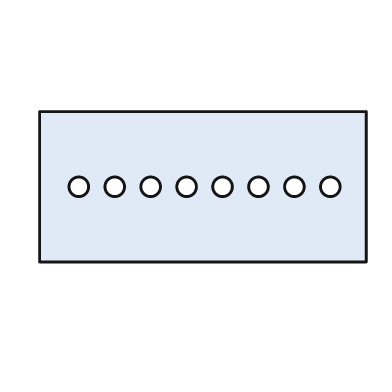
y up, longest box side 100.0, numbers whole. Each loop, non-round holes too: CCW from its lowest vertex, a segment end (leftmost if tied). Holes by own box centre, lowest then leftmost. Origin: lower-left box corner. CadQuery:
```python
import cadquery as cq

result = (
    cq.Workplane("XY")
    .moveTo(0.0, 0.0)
    .lineTo(100.0, 0.0)
    .lineTo(100.0, 46.0)
    .lineTo(0.0, 46.0)
    .close()
    .moveTo(12.0, 23.0)
    .circle(3.0)
    .moveTo(23.0, 23.0)
    .circle(3.0)
    .moveTo(34.0, 23.0)
    .circle(3.0)
    .moveTo(45.0, 23.0)
    .circle(3.0)
    .moveTo(56.0, 23.0)
    .circle(3.0)
    .moveTo(67.0, 23.0)
    .circle(3.0)
    .moveTo(78.0, 23.0)
    .circle(3.0)
    .moveTo(89.0, 23.0)
    .circle(3.0)
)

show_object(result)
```